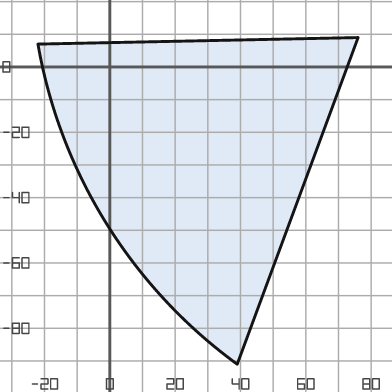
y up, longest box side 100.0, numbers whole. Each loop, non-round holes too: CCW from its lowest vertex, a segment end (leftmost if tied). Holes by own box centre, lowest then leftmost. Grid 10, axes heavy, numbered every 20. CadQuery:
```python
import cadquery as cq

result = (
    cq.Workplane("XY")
    .moveTo(39.0, -91.0)
    .lineTo(76.0, 9.0)
    .lineTo(-22.0, 7.0)
    .threePointArc((-1.0, -48.0), (39.0, -91.0))
    .close()
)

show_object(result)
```